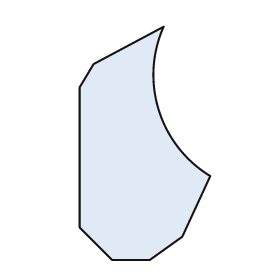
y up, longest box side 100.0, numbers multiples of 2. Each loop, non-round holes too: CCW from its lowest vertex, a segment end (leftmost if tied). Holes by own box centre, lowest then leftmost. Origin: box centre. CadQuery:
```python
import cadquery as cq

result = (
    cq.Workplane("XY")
    .moveTo(-14.0, -50.0)
    .lineTo(2.0, -50.0)
    .lineTo(16.0, -40.0)
    .lineTo(28.0, -14.0)
    .threePointArc((6.0, 14.0), (8.0, 50.0))
    .lineTo(-22.0, 34.0)
    .lineTo(-28.0, 24.0)
    .lineTo(-28.0, -36.0)
    .close()
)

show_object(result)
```